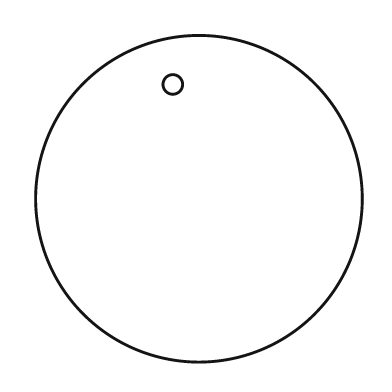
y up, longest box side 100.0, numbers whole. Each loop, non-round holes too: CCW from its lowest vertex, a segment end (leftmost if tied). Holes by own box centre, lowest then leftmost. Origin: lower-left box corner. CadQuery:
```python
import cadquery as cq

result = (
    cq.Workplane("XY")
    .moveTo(50.0, 50.0)
    .circle(50.0)
    .moveTo(42.0, 85.0)
    .circle(3.0)
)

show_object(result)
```